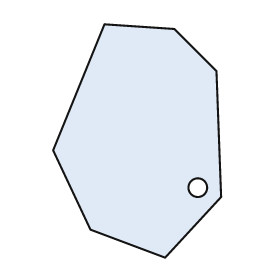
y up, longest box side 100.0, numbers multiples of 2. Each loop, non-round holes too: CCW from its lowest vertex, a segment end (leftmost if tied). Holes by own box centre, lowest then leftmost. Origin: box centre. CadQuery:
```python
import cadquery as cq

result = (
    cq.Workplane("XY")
    .moveTo(12.0, -50.0)
    .lineTo(36.0, -24.0)
    .lineTo(34.0, 30.0)
    .lineTo(16.0, 48.0)
    .lineTo(-14.0, 50.0)
    .lineTo(-36.0, -4.0)
    .lineTo(-20.0, -38.0)
    .close()
    .moveTo(26.0, -20.0)
    .circle(4.0)
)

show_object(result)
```